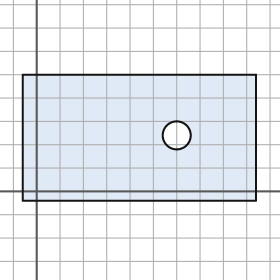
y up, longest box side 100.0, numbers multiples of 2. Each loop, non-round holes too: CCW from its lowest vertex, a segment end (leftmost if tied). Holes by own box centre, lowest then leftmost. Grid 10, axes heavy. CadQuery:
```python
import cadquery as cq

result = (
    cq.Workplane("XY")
    .moveTo(-6.0, -4.0)
    .lineTo(94.0, -4.0)
    .lineTo(94.0, 50.0)
    .lineTo(-6.0, 50.0)
    .close()
    .moveTo(60.0, 24.0)
    .circle(6.0)
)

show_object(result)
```